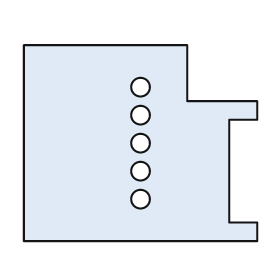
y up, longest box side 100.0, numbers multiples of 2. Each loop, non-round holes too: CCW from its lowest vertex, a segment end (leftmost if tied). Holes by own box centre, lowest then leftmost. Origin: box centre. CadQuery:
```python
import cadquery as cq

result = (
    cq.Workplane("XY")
    .moveTo(-50.0, -42.0)
    .lineTo(50.0, -42.0)
    .lineTo(50.0, -34.0)
    .lineTo(38.0, -34.0)
    .lineTo(38.0, 10.0)
    .lineTo(50.0, 10.0)
    .lineTo(50.0, 18.0)
    .lineTo(20.0, 18.0)
    .lineTo(20.0, 42.0)
    .lineTo(-50.0, 42.0)
    .close()
    .moveTo(0.0, -24.0)
    .circle(4.0)
    .moveTo(0.0, -12.0)
    .circle(4.0)
    .moveTo(0.0, 0.0)
    .circle(4.0)
    .moveTo(0.0, 12.0)
    .circle(4.0)
    .moveTo(0.0, 24.0)
    .circle(4.0)
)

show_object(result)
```